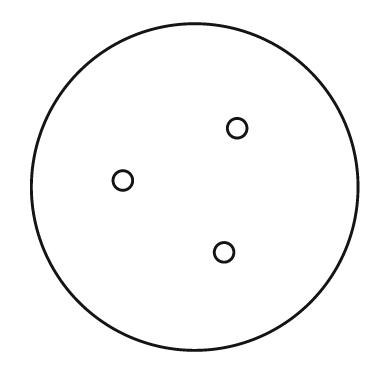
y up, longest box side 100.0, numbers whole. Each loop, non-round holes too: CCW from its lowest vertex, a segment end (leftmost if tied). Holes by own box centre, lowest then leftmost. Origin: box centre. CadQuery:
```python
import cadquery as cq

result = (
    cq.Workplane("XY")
    .moveTo(0.0, 0.0)
    .circle(50.0)
    .moveTo(9.0, -20.0)
    .circle(3.0)
    .moveTo(-22.0, 2.0)
    .circle(3.0)
    .moveTo(13.0, 18.0)
    .circle(3.0)
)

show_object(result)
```